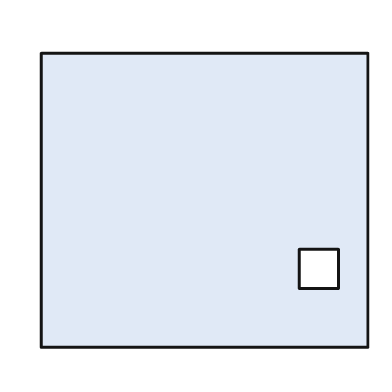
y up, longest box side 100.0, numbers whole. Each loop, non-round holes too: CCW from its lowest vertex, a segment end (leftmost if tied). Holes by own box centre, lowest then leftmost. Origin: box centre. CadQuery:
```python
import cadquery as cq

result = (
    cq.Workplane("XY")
    .moveTo(-50.0, -45.0)
    .lineTo(50.0, -45.0)
    .lineTo(50.0, 45.0)
    .lineTo(-50.0, 45.0)
    .close()
    .moveTo(29.0, -27.0)
    .lineTo(41.0, -27.0)
    .lineTo(41.0, -15.0)
    .lineTo(29.0, -15.0)
    .close()
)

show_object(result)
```